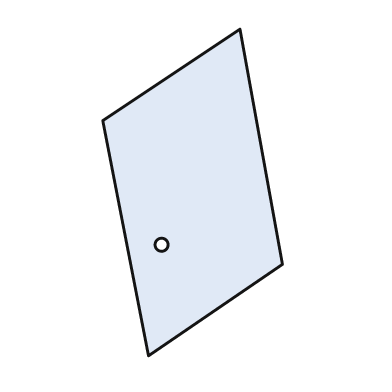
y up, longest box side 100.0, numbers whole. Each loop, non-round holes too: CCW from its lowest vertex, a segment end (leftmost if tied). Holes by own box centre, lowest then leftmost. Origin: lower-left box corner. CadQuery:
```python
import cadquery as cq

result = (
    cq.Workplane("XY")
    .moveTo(14.0, 0.0)
    .lineTo(55.0, 28.0)
    .lineTo(42.0, 100.0)
    .lineTo(0.0, 72.0)
    .close()
    .moveTo(18.0, 34.0)
    .circle(2.0)
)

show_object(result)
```